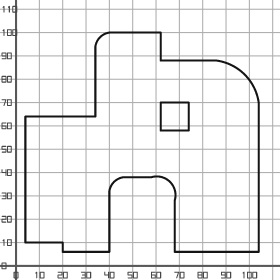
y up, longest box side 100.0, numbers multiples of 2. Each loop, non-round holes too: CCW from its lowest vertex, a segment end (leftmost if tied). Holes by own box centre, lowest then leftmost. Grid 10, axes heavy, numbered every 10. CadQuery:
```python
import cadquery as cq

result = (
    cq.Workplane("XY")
    .moveTo(20.0, 6.0)
    .lineTo(40.0, 6.0)
    .lineTo(40.0, 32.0)
    .threePointArc((42.0, 36.0), (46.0, 38.0))
    .lineTo(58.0, 38.0)
    .threePointArc((66.0, 36.0), (68.0, 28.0))
    .lineTo(68.0, 6.0)
    .lineTo(104.0, 6.0)
    .lineTo(104.0, 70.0)
    .threePointArc((98.0, 82.0), (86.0, 88.0))
    .lineTo(62.0, 88.0)
    .lineTo(62.0, 100.0)
    .lineTo(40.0, 100.0)
    .threePointArc((36.0, 98.0), (34.0, 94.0))
    .lineTo(34.0, 64.0)
    .lineTo(4.0, 64.0)
    .lineTo(4.0, 10.0)
    .lineTo(20.0, 10.0)
    .close()
    .moveTo(62.0, 58.0)
    .lineTo(74.0, 58.0)
    .lineTo(74.0, 70.0)
    .lineTo(62.0, 70.0)
    .close()
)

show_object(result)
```